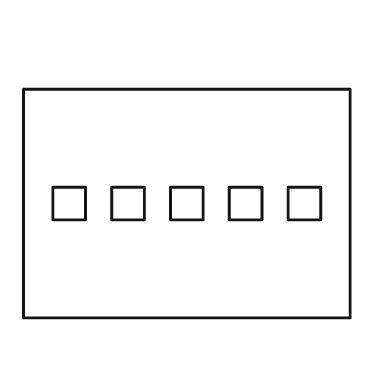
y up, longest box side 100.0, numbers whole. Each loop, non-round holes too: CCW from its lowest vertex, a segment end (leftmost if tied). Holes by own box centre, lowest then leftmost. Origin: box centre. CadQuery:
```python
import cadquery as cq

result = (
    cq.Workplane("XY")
    .moveTo(-50.0, -35.0)
    .lineTo(50.0, -35.0)
    .lineTo(50.0, 35.0)
    .lineTo(-50.0, 35.0)
    .close()
    .moveTo(-41.0, -5.0)
    .lineTo(-31.0, -5.0)
    .lineTo(-31.0, 5.0)
    .lineTo(-41.0, 5.0)
    .close()
    .moveTo(-23.0, -5.0)
    .lineTo(-13.0, -5.0)
    .lineTo(-13.0, 5.0)
    .lineTo(-23.0, 5.0)
    .close()
    .moveTo(-5.0, -5.0)
    .lineTo(5.0, -5.0)
    .lineTo(5.0, 5.0)
    .lineTo(-5.0, 5.0)
    .close()
    .moveTo(13.0, -5.0)
    .lineTo(23.0, -5.0)
    .lineTo(23.0, 5.0)
    .lineTo(13.0, 5.0)
    .close()
    .moveTo(31.0, -5.0)
    .lineTo(41.0, -5.0)
    .lineTo(41.0, 5.0)
    .lineTo(31.0, 5.0)
    .close()
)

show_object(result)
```